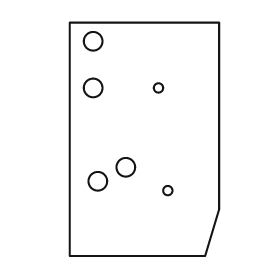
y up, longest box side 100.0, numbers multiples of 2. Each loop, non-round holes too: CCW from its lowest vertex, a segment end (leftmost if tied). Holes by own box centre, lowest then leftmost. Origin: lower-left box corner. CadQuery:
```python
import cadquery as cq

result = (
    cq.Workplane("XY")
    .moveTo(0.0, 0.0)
    .lineTo(58.0, 0.0)
    .lineTo(64.0, 20.0)
    .lineTo(64.0, 100.0)
    .lineTo(0.0, 100.0)
    .close()
    .moveTo(42.0, 28.0)
    .circle(2.0)
    .moveTo(12.0, 32.0)
    .circle(4.0)
    .moveTo(24.0, 38.0)
    .circle(4.0)
    .moveTo(10.0, 72.0)
    .circle(4.0)
    .moveTo(38.0, 72.0)
    .circle(2.0)
    .moveTo(10.0, 92.0)
    .circle(4.0)
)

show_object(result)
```